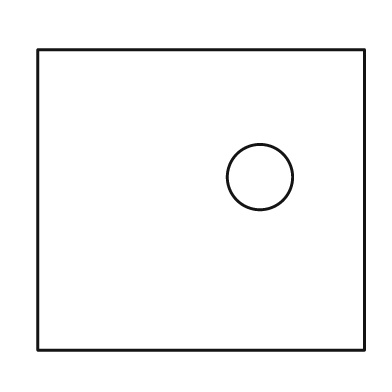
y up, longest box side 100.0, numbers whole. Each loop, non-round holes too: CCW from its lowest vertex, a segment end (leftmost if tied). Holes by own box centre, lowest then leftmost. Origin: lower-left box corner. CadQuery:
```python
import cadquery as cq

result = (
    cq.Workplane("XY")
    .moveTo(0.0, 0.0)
    .lineTo(100.0, 0.0)
    .lineTo(100.0, 92.0)
    .lineTo(0.0, 92.0)
    .close()
    .moveTo(68.0, 53.0)
    .circle(10.0)
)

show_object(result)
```